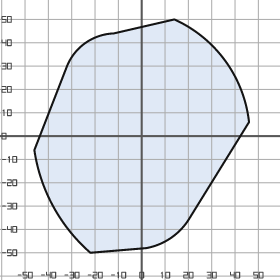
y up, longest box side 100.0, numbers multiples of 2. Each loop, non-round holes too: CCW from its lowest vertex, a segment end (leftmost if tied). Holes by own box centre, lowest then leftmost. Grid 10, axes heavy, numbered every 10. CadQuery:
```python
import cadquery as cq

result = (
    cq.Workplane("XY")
    .moveTo(-22.0, -50.0)
    .lineTo(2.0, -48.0)
    .threePointArc((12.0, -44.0), (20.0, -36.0))
    .lineTo(46.0, 6.0)
    .threePointArc((36.0, 32.0), (14.0, 50.0))
    .lineTo(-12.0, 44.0)
    .threePointArc((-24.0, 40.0), (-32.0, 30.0))
    .lineTo(-46.0, -6.0)
    .threePointArc((-38.0, -30.0), (-22.0, -50.0))
    .close()
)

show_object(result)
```